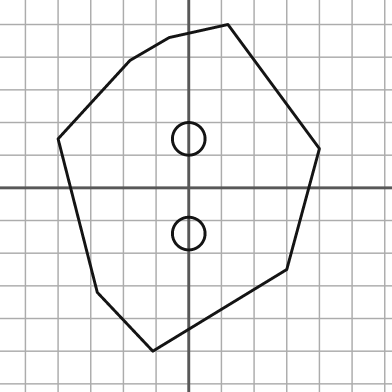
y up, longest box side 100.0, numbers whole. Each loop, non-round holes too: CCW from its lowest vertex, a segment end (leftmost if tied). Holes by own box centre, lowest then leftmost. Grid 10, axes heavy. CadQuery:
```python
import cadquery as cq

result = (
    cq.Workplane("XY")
    .moveTo(-11.0, -50.0)
    .lineTo(30.0, -25.0)
    .lineTo(40.0, 12.0)
    .lineTo(12.0, 50.0)
    .lineTo(-6.0, 46.0)
    .lineTo(-18.0, 39.0)
    .lineTo(-40.0, 15.0)
    .lineTo(-28.0, -32.0)
    .close()
    .moveTo(0.0, -14.0)
    .circle(5.0)
    .moveTo(0.0, 15.0)
    .circle(5.0)
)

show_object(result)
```